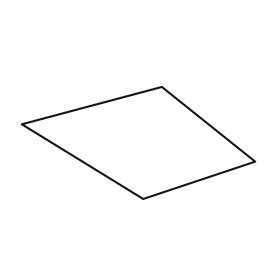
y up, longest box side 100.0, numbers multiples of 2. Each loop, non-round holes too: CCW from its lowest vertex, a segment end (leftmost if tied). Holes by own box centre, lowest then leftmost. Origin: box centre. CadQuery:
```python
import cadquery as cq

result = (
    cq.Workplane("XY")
    .moveTo(2.0, -24.0)
    .lineTo(50.0, -8.0)
    .lineTo(10.0, 24.0)
    .lineTo(-50.0, 8.0)
    .close()
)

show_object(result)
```